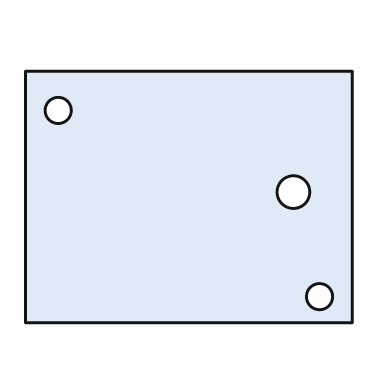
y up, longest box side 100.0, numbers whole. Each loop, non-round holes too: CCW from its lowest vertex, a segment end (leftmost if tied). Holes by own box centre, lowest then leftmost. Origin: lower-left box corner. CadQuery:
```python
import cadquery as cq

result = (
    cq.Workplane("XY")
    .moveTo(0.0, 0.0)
    .lineTo(100.0, 0.0)
    .lineTo(100.0, 77.0)
    .lineTo(0.0, 77.0)
    .close()
    .moveTo(90.0, 8.0)
    .circle(4.0)
    .moveTo(82.0, 40.0)
    .circle(5.0)
    .moveTo(10.0, 65.0)
    .circle(4.0)
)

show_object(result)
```